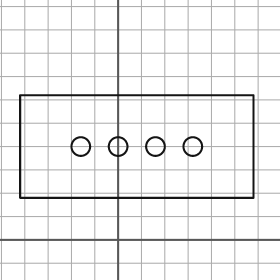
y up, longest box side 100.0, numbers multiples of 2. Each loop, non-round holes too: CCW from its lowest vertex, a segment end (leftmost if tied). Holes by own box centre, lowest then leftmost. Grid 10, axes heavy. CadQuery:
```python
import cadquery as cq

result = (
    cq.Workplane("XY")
    .moveTo(-42.0, 18.0)
    .lineTo(58.0, 18.0)
    .lineTo(58.0, 62.0)
    .lineTo(-42.0, 62.0)
    .close()
    .moveTo(-16.0, 40.0)
    .circle(4.0)
    .moveTo(0.0, 40.0)
    .circle(4.0)
    .moveTo(16.0, 40.0)
    .circle(4.0)
    .moveTo(32.0, 40.0)
    .circle(4.0)
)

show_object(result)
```